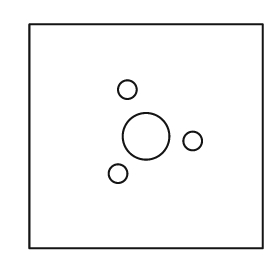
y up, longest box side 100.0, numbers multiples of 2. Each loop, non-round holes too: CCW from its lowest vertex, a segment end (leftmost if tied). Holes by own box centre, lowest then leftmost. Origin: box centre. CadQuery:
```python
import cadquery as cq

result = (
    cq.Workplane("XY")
    .moveTo(-50.0, -48.0)
    .lineTo(50.0, -48.0)
    .lineTo(50.0, 48.0)
    .lineTo(-50.0, 48.0)
    .close()
    .moveTo(-12.0, -16.0)
    .circle(4.0)
    .moveTo(20.0, -2.0)
    .circle(4.0)
    .moveTo(0.0, 0.0)
    .circle(10.0)
    .moveTo(-8.0, 20.0)
    .circle(4.0)
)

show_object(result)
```